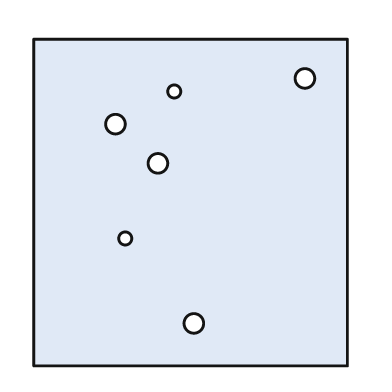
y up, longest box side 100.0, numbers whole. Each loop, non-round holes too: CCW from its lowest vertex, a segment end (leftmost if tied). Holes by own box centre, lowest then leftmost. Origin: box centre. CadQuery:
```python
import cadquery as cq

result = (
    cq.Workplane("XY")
    .moveTo(-48.0, -50.0)
    .lineTo(48.0, -50.0)
    .lineTo(48.0, 50.0)
    .lineTo(-48.0, 50.0)
    .close()
    .moveTo(1.0, -37.0)
    .circle(3.0)
    .moveTo(-20.0, -11.0)
    .circle(2.0)
    .moveTo(-10.0, 12.0)
    .circle(3.0)
    .moveTo(-23.0, 24.0)
    .circle(3.0)
    .moveTo(-5.0, 34.0)
    .circle(2.0)
    .moveTo(35.0, 38.0)
    .circle(3.0)
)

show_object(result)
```